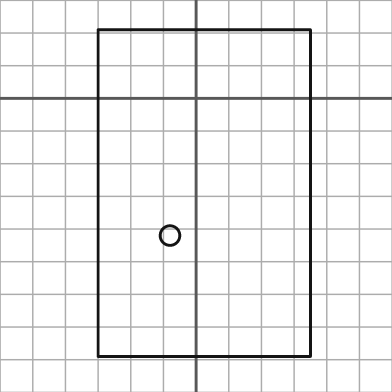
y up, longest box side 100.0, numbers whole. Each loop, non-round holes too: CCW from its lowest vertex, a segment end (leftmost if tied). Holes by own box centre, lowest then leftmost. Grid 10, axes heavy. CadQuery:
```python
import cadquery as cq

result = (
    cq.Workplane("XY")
    .moveTo(-30.0, -79.0)
    .lineTo(35.0, -79.0)
    .lineTo(35.0, 21.0)
    .lineTo(-30.0, 21.0)
    .close()
    .moveTo(-8.0, -42.0)
    .circle(3.0)
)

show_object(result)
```